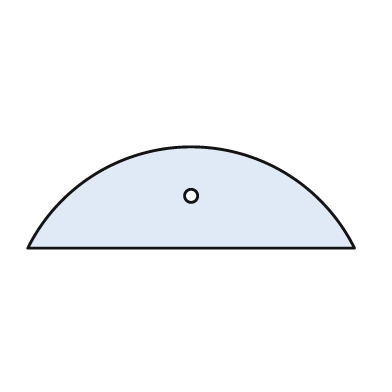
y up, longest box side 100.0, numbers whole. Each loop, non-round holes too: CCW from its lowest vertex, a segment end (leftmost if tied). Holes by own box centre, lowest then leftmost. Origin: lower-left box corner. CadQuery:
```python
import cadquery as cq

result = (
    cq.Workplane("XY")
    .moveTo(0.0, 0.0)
    .lineTo(100.0, 0.0)
    .threePointArc((50.0, 31.0), (0.0, 0.0))
    .close()
    .moveTo(50.0, 16.0)
    .circle(2.0)
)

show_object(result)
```